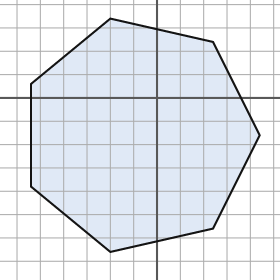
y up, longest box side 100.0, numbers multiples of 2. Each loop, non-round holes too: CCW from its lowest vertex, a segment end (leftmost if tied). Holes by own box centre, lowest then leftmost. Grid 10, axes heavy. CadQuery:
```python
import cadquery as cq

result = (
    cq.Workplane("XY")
    .moveTo(-20.0, -66.0)
    .lineTo(24.0, -56.0)
    .lineTo(44.0, -16.0)
    .lineTo(24.0, 24.0)
    .lineTo(-20.0, 34.0)
    .lineTo(-54.0, 6.0)
    .lineTo(-54.0, -38.0)
    .close()
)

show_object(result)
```